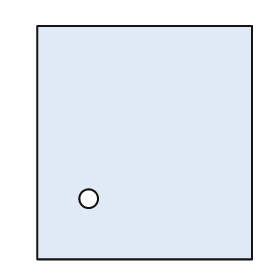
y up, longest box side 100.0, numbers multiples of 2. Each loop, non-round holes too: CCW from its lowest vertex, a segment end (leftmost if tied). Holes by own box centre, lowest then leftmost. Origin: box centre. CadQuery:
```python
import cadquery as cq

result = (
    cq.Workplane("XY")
    .moveTo(-46.0, -50.0)
    .lineTo(46.0, -50.0)
    .lineTo(46.0, 50.0)
    .lineTo(-46.0, 50.0)
    .close()
    .moveTo(-24.0, -24.0)
    .circle(4.0)
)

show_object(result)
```